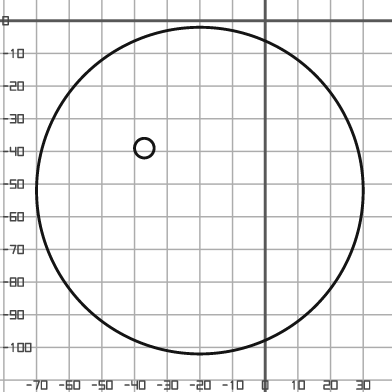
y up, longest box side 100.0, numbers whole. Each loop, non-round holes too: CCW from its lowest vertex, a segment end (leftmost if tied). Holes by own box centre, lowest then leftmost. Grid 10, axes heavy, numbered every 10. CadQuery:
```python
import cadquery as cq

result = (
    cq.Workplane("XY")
    .moveTo(-20.0, -52.0)
    .circle(50.0)
    .moveTo(-37.0, -39.0)
    .circle(3.0)
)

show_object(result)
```